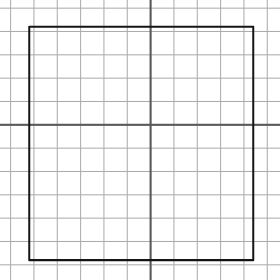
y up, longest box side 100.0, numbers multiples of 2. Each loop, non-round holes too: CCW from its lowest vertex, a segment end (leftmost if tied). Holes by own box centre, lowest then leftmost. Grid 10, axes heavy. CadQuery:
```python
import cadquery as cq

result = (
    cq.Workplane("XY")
    .moveTo(-52.0, -58.0)
    .lineTo(44.0, -58.0)
    .lineTo(44.0, 42.0)
    .lineTo(-52.0, 42.0)
    .close()
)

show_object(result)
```